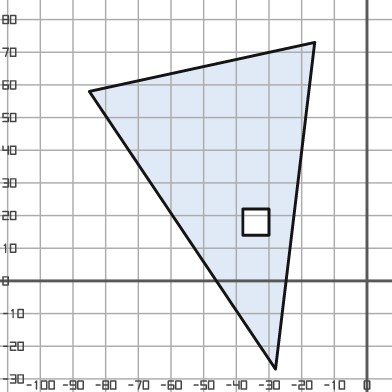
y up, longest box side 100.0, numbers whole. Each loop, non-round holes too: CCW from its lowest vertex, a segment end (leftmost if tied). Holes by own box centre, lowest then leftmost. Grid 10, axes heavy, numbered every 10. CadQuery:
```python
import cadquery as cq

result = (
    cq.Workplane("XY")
    .moveTo(-28.0, -27.0)
    .lineTo(-16.0, 73.0)
    .lineTo(-85.0, 58.0)
    .close()
    .moveTo(-38.0, 14.0)
    .lineTo(-30.0, 14.0)
    .lineTo(-30.0, 22.0)
    .lineTo(-38.0, 22.0)
    .close()
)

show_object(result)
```